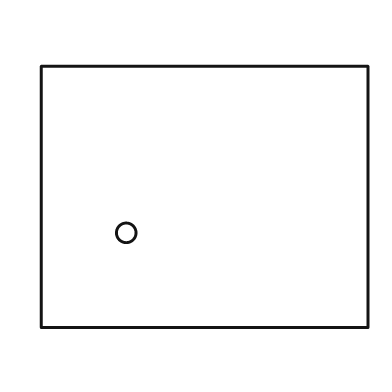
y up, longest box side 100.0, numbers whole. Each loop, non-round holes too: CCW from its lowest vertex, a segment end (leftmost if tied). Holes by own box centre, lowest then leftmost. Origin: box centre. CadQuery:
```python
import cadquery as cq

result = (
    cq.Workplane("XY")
    .moveTo(-50.0, -40.0)
    .lineTo(50.0, -40.0)
    .lineTo(50.0, 40.0)
    .lineTo(-50.0, 40.0)
    .close()
    .moveTo(-24.0, -11.0)
    .circle(3.0)
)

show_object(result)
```